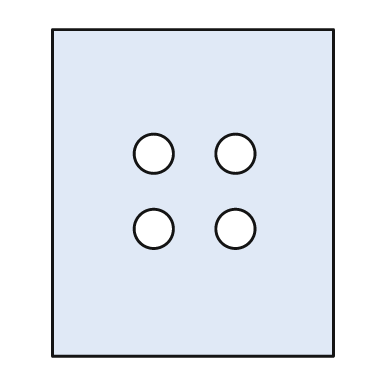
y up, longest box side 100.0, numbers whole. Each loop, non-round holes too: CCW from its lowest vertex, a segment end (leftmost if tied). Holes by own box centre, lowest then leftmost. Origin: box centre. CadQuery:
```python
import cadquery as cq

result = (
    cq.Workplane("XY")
    .moveTo(-43.0, -50.0)
    .lineTo(43.0, -50.0)
    .lineTo(43.0, 50.0)
    .lineTo(-43.0, 50.0)
    .close()
    .moveTo(-12.0, -11.0)
    .circle(6.0)
    .moveTo(13.0, -11.0)
    .circle(6.0)
    .moveTo(-12.0, 12.0)
    .circle(6.0)
    .moveTo(13.0, 12.0)
    .circle(6.0)
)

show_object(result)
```